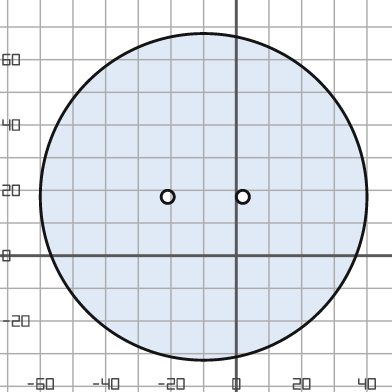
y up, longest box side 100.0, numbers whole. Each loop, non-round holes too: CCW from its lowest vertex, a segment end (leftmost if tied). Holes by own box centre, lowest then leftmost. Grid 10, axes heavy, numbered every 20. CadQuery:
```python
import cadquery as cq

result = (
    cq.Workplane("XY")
    .moveTo(-10.0, 18.0)
    .circle(50.0)
    .moveTo(-21.0, 18.0)
    .circle(2.0)
    .moveTo(2.0, 18.0)
    .circle(2.0)
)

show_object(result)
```